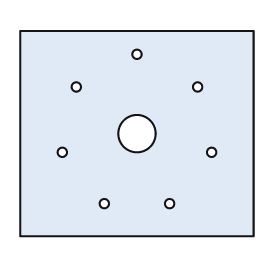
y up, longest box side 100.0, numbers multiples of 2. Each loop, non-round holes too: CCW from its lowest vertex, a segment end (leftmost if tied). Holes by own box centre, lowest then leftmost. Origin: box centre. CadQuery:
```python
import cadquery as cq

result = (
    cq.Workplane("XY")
    .moveTo(-50.0, -44.0)
    .lineTo(50.0, -44.0)
    .lineTo(50.0, 44.0)
    .lineTo(-50.0, 44.0)
    .close()
    .moveTo(-14.0, -30.0)
    .circle(2.0)
    .moveTo(14.0, -30.0)
    .circle(2.0)
    .moveTo(-32.0, -8.0)
    .circle(2.0)
    .moveTo(32.0, -8.0)
    .circle(2.0)
    .moveTo(0.0, 0.0)
    .circle(8.0)
    .moveTo(-26.0, 20.0)
    .circle(2.0)
    .moveTo(26.0, 20.0)
    .circle(2.0)
    .moveTo(0.0, 34.0)
    .circle(2.0)
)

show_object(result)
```